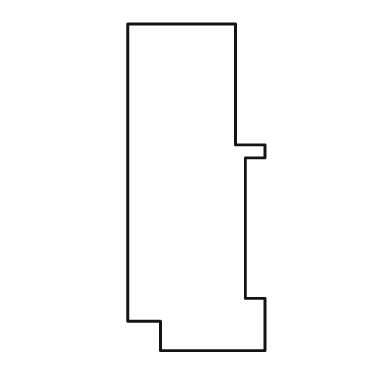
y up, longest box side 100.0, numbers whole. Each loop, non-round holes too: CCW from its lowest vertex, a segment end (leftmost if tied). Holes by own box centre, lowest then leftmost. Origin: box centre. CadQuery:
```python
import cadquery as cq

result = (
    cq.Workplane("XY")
    .moveTo(-11.0, -50.0)
    .lineTo(21.0, -50.0)
    .lineTo(21.0, -34.0)
    .lineTo(15.0, -34.0)
    .lineTo(15.0, 9.0)
    .lineTo(21.0, 9.0)
    .lineTo(21.0, 13.0)
    .lineTo(12.0, 13.0)
    .lineTo(12.0, 50.0)
    .lineTo(-21.0, 50.0)
    .lineTo(-21.0, -41.0)
    .lineTo(-11.0, -41.0)
    .close()
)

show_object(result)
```